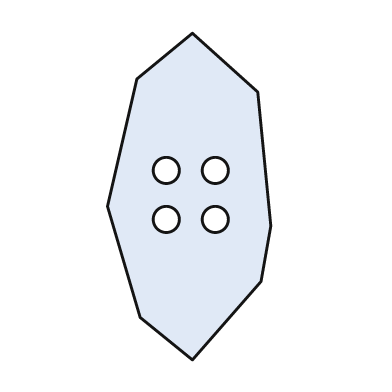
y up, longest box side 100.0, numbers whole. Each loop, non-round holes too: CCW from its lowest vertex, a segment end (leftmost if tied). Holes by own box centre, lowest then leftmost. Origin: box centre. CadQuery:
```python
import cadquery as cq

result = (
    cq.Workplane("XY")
    .moveTo(1.0, -50.0)
    .lineTo(22.0, -26.0)
    .lineTo(25.0, -9.0)
    .lineTo(21.0, 32.0)
    .lineTo(1.0, 50.0)
    .lineTo(-16.0, 36.0)
    .lineTo(-25.0, -3.0)
    .lineTo(-15.0, -37.0)
    .close()
    .moveTo(-7.0, -7.0)
    .circle(4.0)
    .moveTo(8.0, -7.0)
    .circle(4.0)
    .moveTo(-7.0, 8.0)
    .circle(4.0)
    .moveTo(8.0, 8.0)
    .circle(4.0)
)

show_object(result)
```